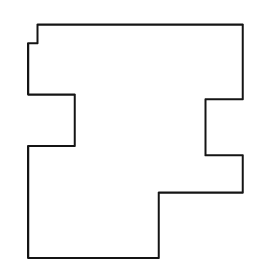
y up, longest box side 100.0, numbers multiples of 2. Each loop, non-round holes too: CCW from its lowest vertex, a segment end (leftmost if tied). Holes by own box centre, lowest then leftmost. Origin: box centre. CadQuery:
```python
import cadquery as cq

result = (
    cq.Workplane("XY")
    .moveTo(-46.0, -50.0)
    .lineTo(10.0, -50.0)
    .lineTo(10.0, -22.0)
    .lineTo(46.0, -22.0)
    .lineTo(46.0, -6.0)
    .lineTo(30.0, -6.0)
    .lineTo(30.0, 18.0)
    .lineTo(46.0, 18.0)
    .lineTo(46.0, 50.0)
    .lineTo(-42.0, 50.0)
    .lineTo(-42.0, 42.0)
    .lineTo(-46.0, 42.0)
    .lineTo(-46.0, 20.0)
    .lineTo(-26.0, 20.0)
    .lineTo(-26.0, -2.0)
    .lineTo(-46.0, -2.0)
    .close()
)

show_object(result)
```